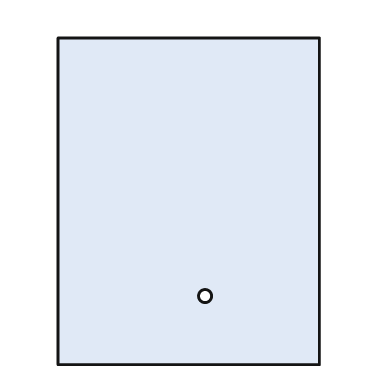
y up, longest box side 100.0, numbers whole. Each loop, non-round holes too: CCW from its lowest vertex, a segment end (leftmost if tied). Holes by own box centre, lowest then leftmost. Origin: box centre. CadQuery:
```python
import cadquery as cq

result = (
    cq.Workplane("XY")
    .moveTo(-40.0, -50.0)
    .lineTo(40.0, -50.0)
    .lineTo(40.0, 50.0)
    .lineTo(-40.0, 50.0)
    .close()
    .moveTo(5.0, -29.0)
    .circle(2.0)
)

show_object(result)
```